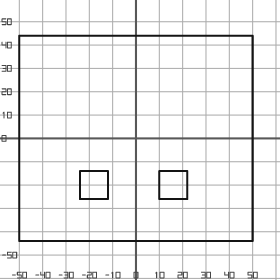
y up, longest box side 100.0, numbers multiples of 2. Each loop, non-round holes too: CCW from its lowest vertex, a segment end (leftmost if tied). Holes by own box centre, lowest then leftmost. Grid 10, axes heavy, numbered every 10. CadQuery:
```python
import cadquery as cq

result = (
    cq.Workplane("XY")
    .moveTo(-50.0, -44.0)
    .lineTo(50.0, -44.0)
    .lineTo(50.0, 44.0)
    .lineTo(-50.0, 44.0)
    .close()
    .moveTo(-24.0, -26.0)
    .lineTo(-12.0, -26.0)
    .lineTo(-12.0, -14.0)
    .lineTo(-24.0, -14.0)
    .close()
    .moveTo(10.0, -26.0)
    .lineTo(22.0, -26.0)
    .lineTo(22.0, -14.0)
    .lineTo(10.0, -14.0)
    .close()
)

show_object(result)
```